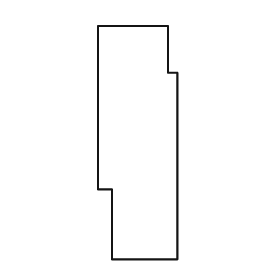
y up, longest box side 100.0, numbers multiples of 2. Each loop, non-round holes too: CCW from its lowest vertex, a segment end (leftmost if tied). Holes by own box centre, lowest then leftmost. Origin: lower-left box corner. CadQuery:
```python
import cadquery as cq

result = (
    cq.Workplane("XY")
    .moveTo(6.0, 0.0)
    .lineTo(34.0, 0.0)
    .lineTo(34.0, 80.0)
    .lineTo(30.0, 80.0)
    .lineTo(30.0, 100.0)
    .lineTo(0.0, 100.0)
    .lineTo(0.0, 30.0)
    .lineTo(6.0, 30.0)
    .close()
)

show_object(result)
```